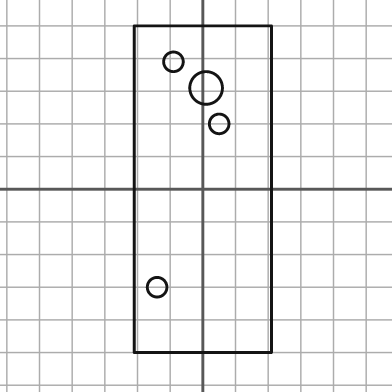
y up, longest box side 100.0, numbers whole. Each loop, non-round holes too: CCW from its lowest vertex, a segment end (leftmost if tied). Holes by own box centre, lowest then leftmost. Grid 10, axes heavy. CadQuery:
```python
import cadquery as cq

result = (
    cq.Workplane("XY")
    .moveTo(-21.0, -50.0)
    .lineTo(21.0, -50.0)
    .lineTo(21.0, 50.0)
    .lineTo(-21.0, 50.0)
    .close()
    .moveTo(-14.0, -30.0)
    .circle(3.0)
    .moveTo(5.0, 20.0)
    .circle(3.0)
    .moveTo(1.0, 31.0)
    .circle(5.0)
    .moveTo(-9.0, 39.0)
    .circle(3.0)
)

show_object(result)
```